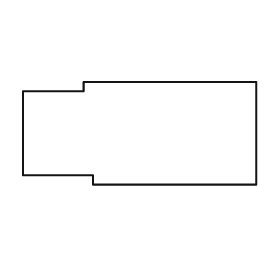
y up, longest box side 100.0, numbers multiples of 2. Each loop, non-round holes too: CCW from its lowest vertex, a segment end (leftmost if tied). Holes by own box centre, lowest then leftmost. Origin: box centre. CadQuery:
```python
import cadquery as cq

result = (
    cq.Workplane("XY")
    .moveTo(-20.0, -22.0)
    .lineTo(50.0, -22.0)
    .lineTo(50.0, 22.0)
    .lineTo(-24.0, 22.0)
    .lineTo(-24.0, 18.0)
    .lineTo(-50.0, 18.0)
    .lineTo(-50.0, -18.0)
    .lineTo(-20.0, -18.0)
    .close()
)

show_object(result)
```